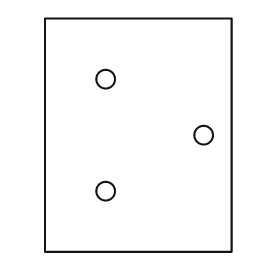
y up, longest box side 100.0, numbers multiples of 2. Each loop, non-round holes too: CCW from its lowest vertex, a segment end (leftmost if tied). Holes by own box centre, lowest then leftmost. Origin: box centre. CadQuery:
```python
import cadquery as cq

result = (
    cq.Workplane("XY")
    .moveTo(-40.0, -50.0)
    .lineTo(40.0, -50.0)
    .lineTo(40.0, 50.0)
    .lineTo(-40.0, 50.0)
    .close()
    .moveTo(-14.0, -24.0)
    .circle(4.0)
    .moveTo(28.0, 0.0)
    .circle(4.0)
    .moveTo(-14.0, 24.0)
    .circle(4.0)
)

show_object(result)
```